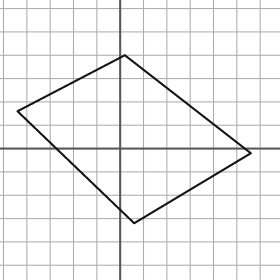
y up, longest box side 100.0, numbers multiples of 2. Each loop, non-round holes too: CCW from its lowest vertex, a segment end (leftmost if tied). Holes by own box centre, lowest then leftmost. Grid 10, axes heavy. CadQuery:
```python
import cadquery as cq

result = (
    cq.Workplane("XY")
    .moveTo(6.0, -32.0)
    .lineTo(56.0, -2.0)
    .lineTo(2.0, 40.0)
    .lineTo(-44.0, 16.0)
    .close()
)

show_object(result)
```